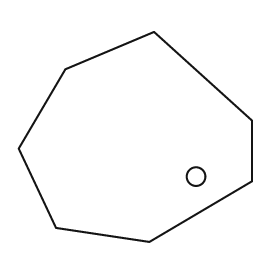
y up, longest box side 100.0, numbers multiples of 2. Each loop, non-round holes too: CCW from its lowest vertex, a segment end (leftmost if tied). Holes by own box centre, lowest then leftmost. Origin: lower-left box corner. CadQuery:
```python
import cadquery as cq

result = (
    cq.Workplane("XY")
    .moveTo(56.0, 0.0)
    .lineTo(100.0, 26.0)
    .lineTo(100.0, 52.0)
    .lineTo(58.0, 90.0)
    .lineTo(20.0, 74.0)
    .lineTo(0.0, 40.0)
    .lineTo(16.0, 6.0)
    .close()
    .moveTo(76.0, 28.0)
    .circle(4.0)
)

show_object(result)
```